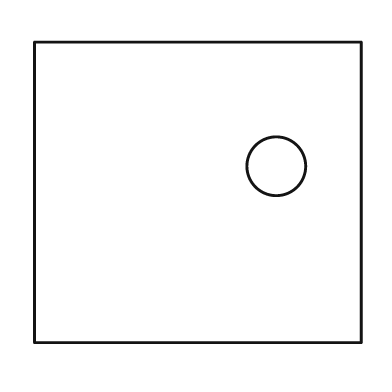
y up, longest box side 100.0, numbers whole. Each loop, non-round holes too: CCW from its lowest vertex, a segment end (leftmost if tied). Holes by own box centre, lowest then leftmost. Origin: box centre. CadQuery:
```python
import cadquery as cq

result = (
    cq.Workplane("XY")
    .moveTo(-50.0, -46.0)
    .lineTo(50.0, -46.0)
    .lineTo(50.0, 46.0)
    .lineTo(-50.0, 46.0)
    .close()
    .moveTo(24.0, 8.0)
    .circle(9.0)
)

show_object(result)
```